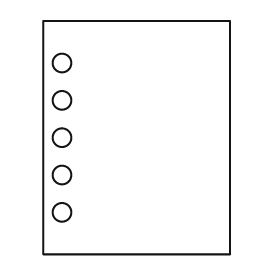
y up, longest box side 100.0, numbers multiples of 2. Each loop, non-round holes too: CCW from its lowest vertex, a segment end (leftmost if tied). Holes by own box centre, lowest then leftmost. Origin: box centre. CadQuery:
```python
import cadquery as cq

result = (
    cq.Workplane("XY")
    .moveTo(-40.0, -50.0)
    .lineTo(40.0, -50.0)
    .lineTo(40.0, 50.0)
    .lineTo(-40.0, 50.0)
    .close()
    .moveTo(-32.0, -32.0)
    .circle(4.0)
    .moveTo(-32.0, -16.0)
    .circle(4.0)
    .moveTo(-32.0, 0.0)
    .circle(4.0)
    .moveTo(-32.0, 16.0)
    .circle(4.0)
    .moveTo(-32.0, 32.0)
    .circle(4.0)
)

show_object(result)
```